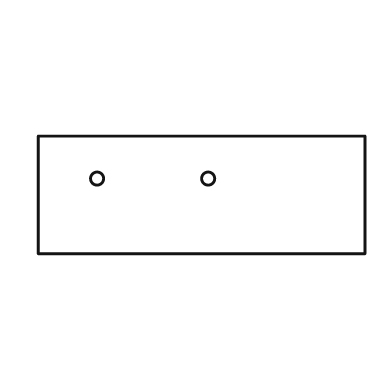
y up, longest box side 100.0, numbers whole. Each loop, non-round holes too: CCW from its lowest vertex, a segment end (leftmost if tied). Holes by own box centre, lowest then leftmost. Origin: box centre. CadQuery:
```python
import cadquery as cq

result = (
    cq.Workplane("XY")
    .moveTo(-50.0, -18.0)
    .lineTo(50.0, -18.0)
    .lineTo(50.0, 18.0)
    .lineTo(-50.0, 18.0)
    .close()
    .moveTo(-32.0, 5.0)
    .circle(2.0)
    .moveTo(2.0, 5.0)
    .circle(2.0)
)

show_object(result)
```